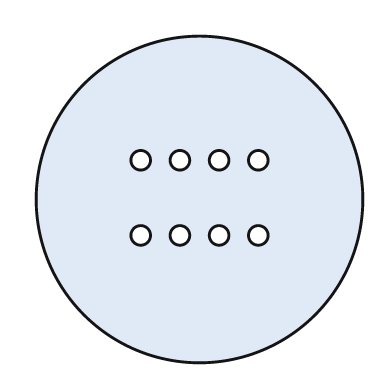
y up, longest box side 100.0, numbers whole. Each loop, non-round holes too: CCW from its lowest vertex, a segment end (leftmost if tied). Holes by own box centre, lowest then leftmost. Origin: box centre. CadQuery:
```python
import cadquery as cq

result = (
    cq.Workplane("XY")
    .moveTo(0.0, 0.0)
    .circle(50.0)
    .moveTo(-18.0, -11.0)
    .circle(3.0)
    .moveTo(-6.0, -11.0)
    .circle(3.0)
    .moveTo(6.0, -11.0)
    .circle(3.0)
    .moveTo(18.0, -11.0)
    .circle(3.0)
    .moveTo(-18.0, 12.0)
    .circle(3.0)
    .moveTo(-6.0, 12.0)
    .circle(3.0)
    .moveTo(6.0, 12.0)
    .circle(3.0)
    .moveTo(18.0, 12.0)
    .circle(3.0)
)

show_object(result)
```